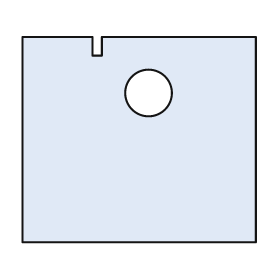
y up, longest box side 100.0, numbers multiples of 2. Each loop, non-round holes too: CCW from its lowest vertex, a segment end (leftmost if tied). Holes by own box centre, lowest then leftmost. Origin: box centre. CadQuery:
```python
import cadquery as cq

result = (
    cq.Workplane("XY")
    .moveTo(-50.0, -44.0)
    .lineTo(50.0, -44.0)
    .lineTo(50.0, 44.0)
    .lineTo(-16.0, 44.0)
    .lineTo(-16.0, 36.0)
    .lineTo(-20.0, 36.0)
    .lineTo(-20.0, 44.0)
    .lineTo(-50.0, 44.0)
    .close()
    .moveTo(4.0, 20.0)
    .circle(10.0)
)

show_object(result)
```